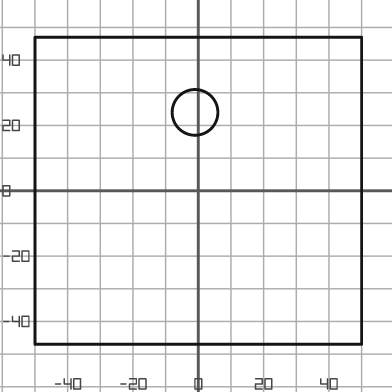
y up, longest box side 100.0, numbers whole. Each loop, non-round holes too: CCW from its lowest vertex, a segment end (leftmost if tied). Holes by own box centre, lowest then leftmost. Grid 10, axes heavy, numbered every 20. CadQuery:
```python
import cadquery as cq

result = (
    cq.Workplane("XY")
    .moveTo(-50.0, -47.0)
    .lineTo(50.0, -47.0)
    .lineTo(50.0, 47.0)
    .lineTo(-50.0, 47.0)
    .close()
    .moveTo(-1.0, 24.0)
    .circle(7.0)
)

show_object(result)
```